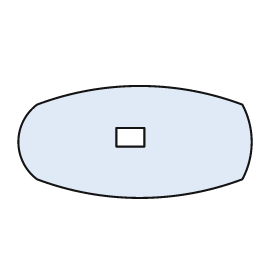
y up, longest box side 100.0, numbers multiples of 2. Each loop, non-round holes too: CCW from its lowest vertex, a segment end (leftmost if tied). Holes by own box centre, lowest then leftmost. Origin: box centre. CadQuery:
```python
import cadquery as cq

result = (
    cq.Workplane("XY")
    .moveTo(-42.0, -16.0)
    .threePointArc((2.0, -24.0), (46.0, -16.0))
    .threePointArc((50.0, 0.0), (46.0, 16.0))
    .threePointArc((2.0, 24.0), (-42.0, 16.0))
    .threePointArc((-50.0, 0.0), (-42.0, -16.0))
    .close()
    .moveTo(-8.0, -2.0)
    .lineTo(4.0, -2.0)
    .lineTo(4.0, 6.0)
    .lineTo(-8.0, 6.0)
    .close()
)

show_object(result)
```